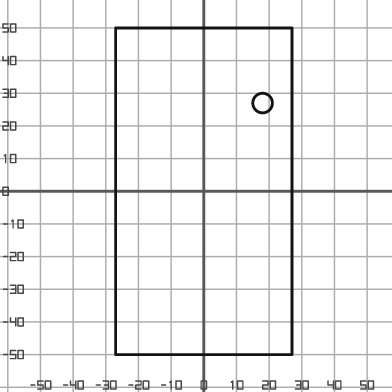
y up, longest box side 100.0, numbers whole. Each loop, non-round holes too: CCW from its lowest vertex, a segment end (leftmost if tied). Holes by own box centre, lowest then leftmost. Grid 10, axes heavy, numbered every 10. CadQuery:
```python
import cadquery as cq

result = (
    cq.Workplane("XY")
    .moveTo(-27.0, -50.0)
    .lineTo(27.0, -50.0)
    .lineTo(27.0, 50.0)
    .lineTo(-27.0, 50.0)
    .close()
    .moveTo(18.0, 27.0)
    .circle(3.0)
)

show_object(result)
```